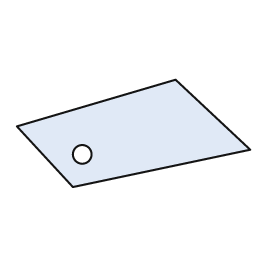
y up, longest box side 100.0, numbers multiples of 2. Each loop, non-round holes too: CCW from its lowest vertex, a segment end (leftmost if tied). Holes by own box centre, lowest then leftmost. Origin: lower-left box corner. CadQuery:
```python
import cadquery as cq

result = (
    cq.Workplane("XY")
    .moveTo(24.0, 0.0)
    .lineTo(100.0, 16.0)
    .lineTo(68.0, 46.0)
    .lineTo(0.0, 26.0)
    .close()
    .moveTo(28.0, 14.0)
    .circle(4.0)
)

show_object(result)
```